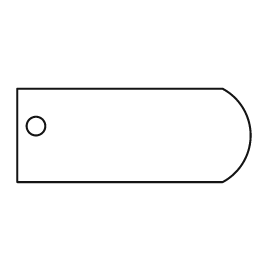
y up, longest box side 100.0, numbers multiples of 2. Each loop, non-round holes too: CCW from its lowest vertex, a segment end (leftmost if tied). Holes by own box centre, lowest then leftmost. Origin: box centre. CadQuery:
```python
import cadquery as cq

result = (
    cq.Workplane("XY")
    .moveTo(-50.0, -20.0)
    .lineTo(38.0, -20.0)
    .threePointArc((50.0, 0.0), (38.0, 20.0))
    .lineTo(-50.0, 20.0)
    .close()
    .moveTo(-42.0, 4.0)
    .circle(4.0)
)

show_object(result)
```